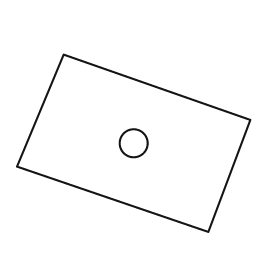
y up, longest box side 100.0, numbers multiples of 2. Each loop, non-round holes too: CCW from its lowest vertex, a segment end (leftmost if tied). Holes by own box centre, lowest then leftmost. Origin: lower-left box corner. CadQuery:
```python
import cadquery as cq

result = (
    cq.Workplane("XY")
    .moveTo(82.0, 0.0)
    .lineTo(100.0, 48.0)
    .lineTo(20.0, 76.0)
    .lineTo(0.0, 28.0)
    .close()
    .moveTo(50.0, 38.0)
    .circle(6.0)
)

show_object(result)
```